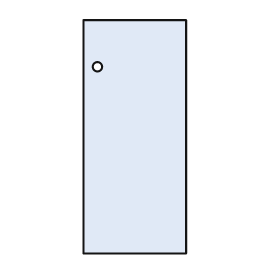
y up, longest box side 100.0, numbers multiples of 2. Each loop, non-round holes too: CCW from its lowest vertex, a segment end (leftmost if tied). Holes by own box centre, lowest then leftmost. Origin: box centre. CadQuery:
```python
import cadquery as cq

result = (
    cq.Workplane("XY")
    .moveTo(-22.0, -50.0)
    .lineTo(22.0, -50.0)
    .lineTo(22.0, 50.0)
    .lineTo(-22.0, 50.0)
    .close()
    .moveTo(-16.0, 30.0)
    .circle(2.0)
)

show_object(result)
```